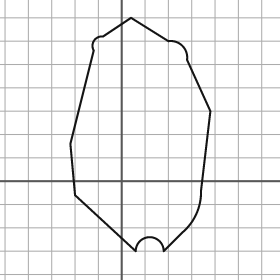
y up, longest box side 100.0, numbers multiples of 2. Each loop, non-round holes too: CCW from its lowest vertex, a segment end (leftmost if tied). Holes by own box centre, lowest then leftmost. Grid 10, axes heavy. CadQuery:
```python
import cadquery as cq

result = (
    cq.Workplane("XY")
    .moveTo(6.0, -30.0)
    .threePointArc((12.0, -24.0), (18.0, -30.0))
    .lineTo(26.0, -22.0)
    .threePointArc((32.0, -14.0), (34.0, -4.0))
    .lineTo(38.0, 30.0)
    .lineTo(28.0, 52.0)
    .threePointArc((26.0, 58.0), (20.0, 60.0))
    .lineTo(4.0, 70.0)
    .lineTo(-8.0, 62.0)
    .threePointArc((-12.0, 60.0), (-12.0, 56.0))
    .lineTo(-22.0, 16.0)
    .lineTo(-20.0, -6.0)
    .close()
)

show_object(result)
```